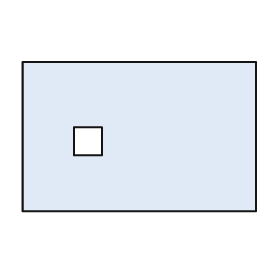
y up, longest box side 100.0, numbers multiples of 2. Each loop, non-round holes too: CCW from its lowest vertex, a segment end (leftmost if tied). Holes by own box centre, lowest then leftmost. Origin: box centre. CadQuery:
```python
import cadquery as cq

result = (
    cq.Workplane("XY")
    .moveTo(-50.0, -32.0)
    .lineTo(50.0, -32.0)
    .lineTo(50.0, 32.0)
    .lineTo(-50.0, 32.0)
    .close()
    .moveTo(-28.0, -8.0)
    .lineTo(-16.0, -8.0)
    .lineTo(-16.0, 4.0)
    .lineTo(-28.0, 4.0)
    .close()
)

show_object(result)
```